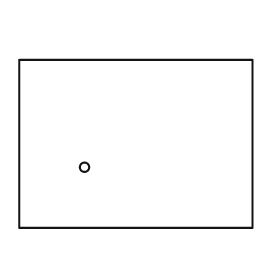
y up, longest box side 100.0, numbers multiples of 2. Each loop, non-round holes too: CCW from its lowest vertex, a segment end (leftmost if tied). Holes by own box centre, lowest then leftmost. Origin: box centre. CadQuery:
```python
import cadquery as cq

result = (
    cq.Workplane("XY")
    .moveTo(-50.0, -36.0)
    .lineTo(50.0, -36.0)
    .lineTo(50.0, 36.0)
    .lineTo(-50.0, 36.0)
    .close()
    .moveTo(-22.0, -10.0)
    .circle(2.0)
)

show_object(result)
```